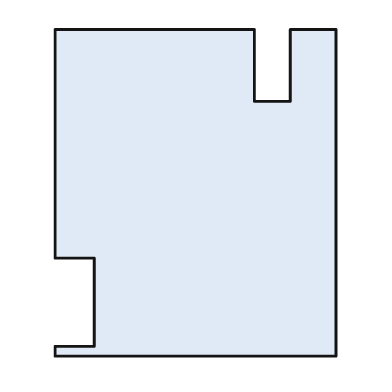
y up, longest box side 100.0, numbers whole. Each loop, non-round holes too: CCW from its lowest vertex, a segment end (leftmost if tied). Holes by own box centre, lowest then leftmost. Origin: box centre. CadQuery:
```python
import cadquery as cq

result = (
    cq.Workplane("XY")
    .moveTo(-43.0, -50.0)
    .lineTo(43.0, -50.0)
    .lineTo(43.0, 50.0)
    .lineTo(29.0, 50.0)
    .lineTo(29.0, 28.0)
    .lineTo(18.0, 28.0)
    .lineTo(18.0, 50.0)
    .lineTo(-43.0, 50.0)
    .lineTo(-43.0, -20.0)
    .lineTo(-31.0, -20.0)
    .lineTo(-31.0, -47.0)
    .lineTo(-43.0, -47.0)
    .close()
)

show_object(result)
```